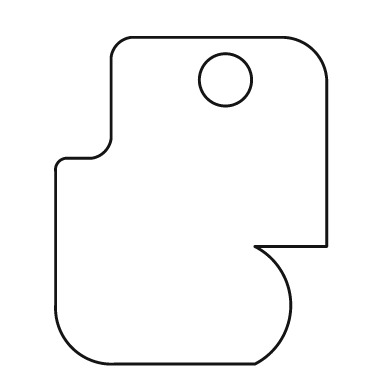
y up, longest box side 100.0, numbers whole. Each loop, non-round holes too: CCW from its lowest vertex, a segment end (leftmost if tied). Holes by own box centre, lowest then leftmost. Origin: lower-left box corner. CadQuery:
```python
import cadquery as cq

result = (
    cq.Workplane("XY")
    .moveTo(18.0, 0.0)
    .lineTo(61.0, 0.0)
    .threePointArc((72.0, 18.0), (61.0, 36.0))
    .lineTo(83.0, 36.0)
    .lineTo(83.0, 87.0)
    .threePointArc((79.0, 96.0), (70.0, 100.0))
    .lineTo(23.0, 100.0)
    .threePointArc((19.0, 98.0), (17.0, 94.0))
    .lineTo(17.0, 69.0)
    .threePointArc((15.0, 65.0), (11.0, 63.0))
    .lineTo(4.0, 63.0)
    .threePointArc((1.0, 62.0), (0.0, 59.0))
    .lineTo(0.0, 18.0)
    .threePointArc((5.0, 5.0), (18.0, 0.0))
    .close()
    .moveTo(52.0, 87.0)
    .circle(8.0)
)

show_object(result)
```